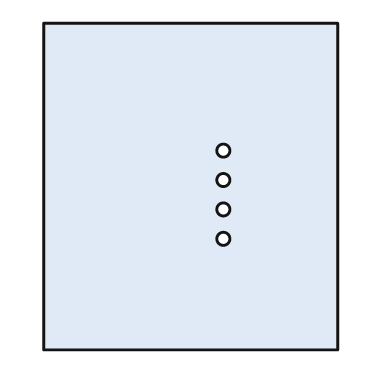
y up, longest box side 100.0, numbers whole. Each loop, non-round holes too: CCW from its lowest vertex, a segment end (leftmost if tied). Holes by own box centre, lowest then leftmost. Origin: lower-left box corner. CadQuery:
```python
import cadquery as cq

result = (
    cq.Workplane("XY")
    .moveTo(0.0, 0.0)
    .lineTo(90.0, 0.0)
    .lineTo(90.0, 100.0)
    .lineTo(0.0, 100.0)
    .close()
    .moveTo(55.0, 34.0)
    .circle(2.0)
    .moveTo(55.0, 43.0)
    .circle(2.0)
    .moveTo(55.0, 52.0)
    .circle(2.0)
    .moveTo(55.0, 61.0)
    .circle(2.0)
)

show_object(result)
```